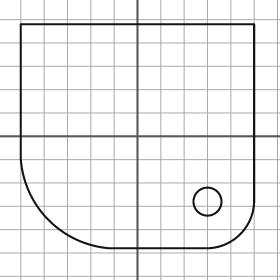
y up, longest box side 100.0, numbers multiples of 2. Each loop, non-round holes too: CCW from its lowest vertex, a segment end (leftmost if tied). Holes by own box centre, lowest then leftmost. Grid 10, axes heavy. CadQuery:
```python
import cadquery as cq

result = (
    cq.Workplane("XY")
    .moveTo(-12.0, -48.0)
    .lineTo(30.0, -48.0)
    .threePointArc((44.0, -42.0), (50.0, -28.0))
    .lineTo(50.0, 48.0)
    .lineTo(-50.0, 48.0)
    .lineTo(-50.0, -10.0)
    .threePointArc((-38.0, -36.0), (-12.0, -48.0))
    .close()
    .moveTo(30.0, -28.0)
    .circle(6.0)
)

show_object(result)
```